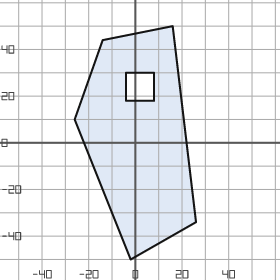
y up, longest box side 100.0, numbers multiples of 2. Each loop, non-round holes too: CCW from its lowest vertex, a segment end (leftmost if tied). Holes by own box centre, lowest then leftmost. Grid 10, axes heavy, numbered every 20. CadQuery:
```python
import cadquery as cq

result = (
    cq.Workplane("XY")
    .moveTo(-2.0, -50.0)
    .lineTo(26.0, -34.0)
    .lineTo(16.0, 50.0)
    .lineTo(-14.0, 44.0)
    .lineTo(-26.0, 10.0)
    .close()
    .moveTo(-4.0, 18.0)
    .lineTo(8.0, 18.0)
    .lineTo(8.0, 30.0)
    .lineTo(-4.0, 30.0)
    .close()
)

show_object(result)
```